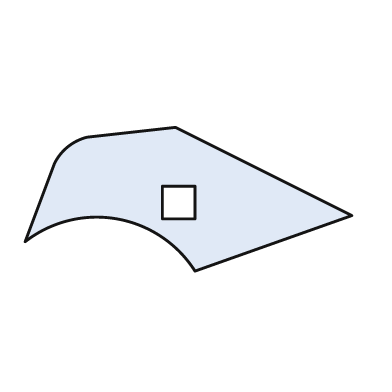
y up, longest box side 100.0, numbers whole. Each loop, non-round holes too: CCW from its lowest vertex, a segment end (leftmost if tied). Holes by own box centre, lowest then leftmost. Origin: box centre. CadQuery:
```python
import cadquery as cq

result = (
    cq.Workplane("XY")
    .moveTo(2.0, -22.0)
    .lineTo(50.0, -5.0)
    .lineTo(-4.0, 22.0)
    .lineTo(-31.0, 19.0)
    .threePointArc((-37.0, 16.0), (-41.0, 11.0))
    .lineTo(-50.0, -13.0)
    .threePointArc((-22.0, -6.0), (2.0, -22.0))
    .close()
    .moveTo(-8.0, -6.0)
    .lineTo(2.0, -6.0)
    .lineTo(2.0, 4.0)
    .lineTo(-8.0, 4.0)
    .close()
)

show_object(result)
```